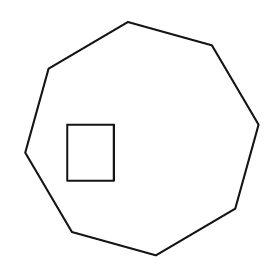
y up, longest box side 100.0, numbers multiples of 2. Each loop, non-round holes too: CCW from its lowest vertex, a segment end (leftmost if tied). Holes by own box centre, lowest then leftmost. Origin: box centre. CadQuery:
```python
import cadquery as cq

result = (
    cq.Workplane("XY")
    .moveTo(6.0, -50.0)
    .lineTo(40.0, -30.0)
    .lineTo(50.0, 6.0)
    .lineTo(30.0, 40.0)
    .lineTo(-6.0, 50.0)
    .lineTo(-40.0, 30.0)
    .lineTo(-50.0, -6.0)
    .lineTo(-30.0, -40.0)
    .close()
    .moveTo(-32.0, -18.0)
    .lineTo(-12.0, -18.0)
    .lineTo(-12.0, 6.0)
    .lineTo(-32.0, 6.0)
    .close()
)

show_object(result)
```